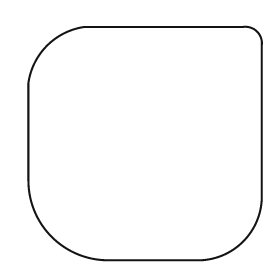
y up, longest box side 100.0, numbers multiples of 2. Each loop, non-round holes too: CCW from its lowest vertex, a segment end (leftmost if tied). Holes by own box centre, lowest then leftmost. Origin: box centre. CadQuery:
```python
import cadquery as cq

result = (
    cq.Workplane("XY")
    .moveTo(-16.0, -50.0)
    .lineTo(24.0, -50.0)
    .threePointArc((42.0, -42.0), (50.0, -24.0))
    .lineTo(50.0, 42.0)
    .threePointArc((48.0, 48.0), (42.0, 50.0))
    .lineTo(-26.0, 50.0)
    .threePointArc((-42.0, 42.0), (-50.0, 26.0))
    .lineTo(-50.0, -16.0)
    .threePointArc((-40.0, -40.0), (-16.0, -50.0))
    .close()
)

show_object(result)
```